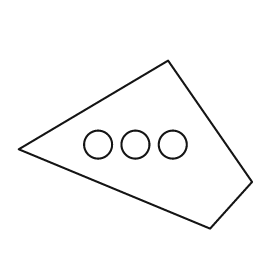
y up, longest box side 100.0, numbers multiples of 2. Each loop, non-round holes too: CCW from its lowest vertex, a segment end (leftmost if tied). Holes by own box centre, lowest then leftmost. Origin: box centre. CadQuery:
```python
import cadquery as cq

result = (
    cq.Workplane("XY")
    .moveTo(32.0, -36.0)
    .lineTo(50.0, -16.0)
    .lineTo(14.0, 36.0)
    .lineTo(-50.0, -2.0)
    .close()
    .moveTo(-16.0, 0.0)
    .circle(6.0)
    .moveTo(0.0, 0.0)
    .circle(6.0)
    .moveTo(16.0, 0.0)
    .circle(6.0)
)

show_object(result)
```